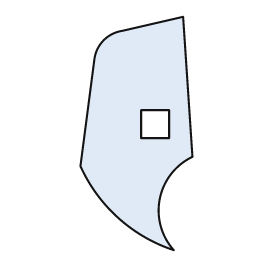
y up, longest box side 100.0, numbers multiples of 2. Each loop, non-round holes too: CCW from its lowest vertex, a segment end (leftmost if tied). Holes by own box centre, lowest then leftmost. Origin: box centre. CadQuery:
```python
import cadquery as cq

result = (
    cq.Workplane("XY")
    .moveTo(16.0, -50.0)
    .threePointArc((10.0, -28.0), (24.0, -10.0))
    .lineTo(20.0, 50.0)
    .lineTo(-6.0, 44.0)
    .threePointArc((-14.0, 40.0), (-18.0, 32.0))
    .lineTo(-24.0, -14.0)
    .threePointArc((-8.0, -36.0), (16.0, -50.0))
    .close()
    .moveTo(2.0, -2.0)
    .lineTo(14.0, -2.0)
    .lineTo(14.0, 10.0)
    .lineTo(2.0, 10.0)
    .close()
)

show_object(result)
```